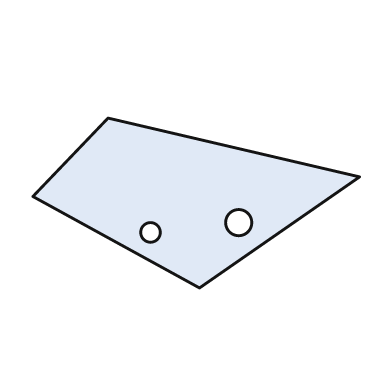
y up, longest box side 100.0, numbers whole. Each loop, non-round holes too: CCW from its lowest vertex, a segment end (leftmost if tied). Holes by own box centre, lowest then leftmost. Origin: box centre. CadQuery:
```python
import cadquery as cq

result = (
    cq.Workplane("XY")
    .moveTo(1.0, -26.0)
    .lineTo(50.0, 8.0)
    .lineTo(-27.0, 26.0)
    .lineTo(-50.0, 2.0)
    .close()
    .moveTo(-14.0, -9.0)
    .circle(3.0)
    .moveTo(13.0, -6.0)
    .circle(4.0)
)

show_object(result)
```